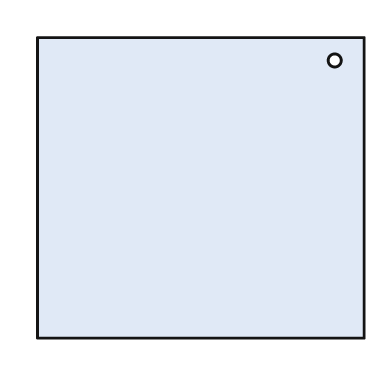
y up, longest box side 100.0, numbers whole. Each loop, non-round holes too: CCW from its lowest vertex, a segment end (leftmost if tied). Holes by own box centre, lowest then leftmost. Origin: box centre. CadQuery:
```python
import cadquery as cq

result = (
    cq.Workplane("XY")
    .moveTo(-50.0, -46.0)
    .lineTo(50.0, -46.0)
    .lineTo(50.0, 46.0)
    .lineTo(-50.0, 46.0)
    .close()
    .moveTo(41.0, 39.0)
    .circle(2.0)
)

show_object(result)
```